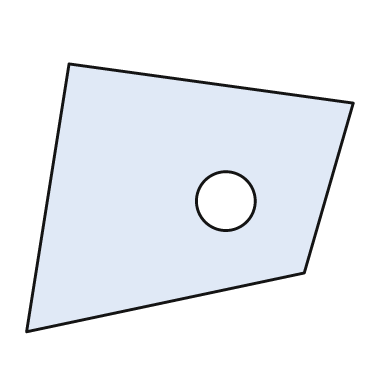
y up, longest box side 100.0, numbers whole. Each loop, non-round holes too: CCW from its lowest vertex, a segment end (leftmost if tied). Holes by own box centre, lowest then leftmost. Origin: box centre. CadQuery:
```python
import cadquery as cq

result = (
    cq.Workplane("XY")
    .moveTo(-50.0, -41.0)
    .lineTo(35.0, -23.0)
    .lineTo(50.0, 29.0)
    .lineTo(-37.0, 41.0)
    .close()
    .moveTo(11.0, -1.0)
    .circle(9.0)
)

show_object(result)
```